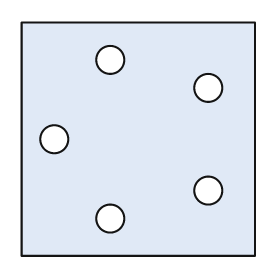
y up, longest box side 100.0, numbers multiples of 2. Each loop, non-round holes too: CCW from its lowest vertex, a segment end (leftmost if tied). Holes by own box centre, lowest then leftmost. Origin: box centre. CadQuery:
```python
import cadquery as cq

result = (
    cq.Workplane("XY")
    .moveTo(-50.0, -50.0)
    .lineTo(50.0, -50.0)
    .lineTo(50.0, 50.0)
    .lineTo(-50.0, 50.0)
    .close()
    .moveTo(-12.0, -34.0)
    .circle(6.0)
    .moveTo(30.0, -22.0)
    .circle(6.0)
    .moveTo(-36.0, 0.0)
    .circle(6.0)
    .moveTo(30.0, 22.0)
    .circle(6.0)
    .moveTo(-12.0, 34.0)
    .circle(6.0)
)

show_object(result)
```